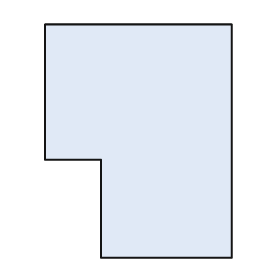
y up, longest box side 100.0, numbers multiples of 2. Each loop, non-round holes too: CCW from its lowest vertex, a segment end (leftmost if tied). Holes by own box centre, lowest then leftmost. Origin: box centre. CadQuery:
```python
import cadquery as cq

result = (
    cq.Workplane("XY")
    .moveTo(-16.0, -50.0)
    .lineTo(40.0, -50.0)
    .lineTo(40.0, 50.0)
    .lineTo(-40.0, 50.0)
    .lineTo(-40.0, -8.0)
    .lineTo(-16.0, -8.0)
    .close()
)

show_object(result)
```